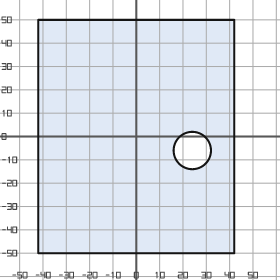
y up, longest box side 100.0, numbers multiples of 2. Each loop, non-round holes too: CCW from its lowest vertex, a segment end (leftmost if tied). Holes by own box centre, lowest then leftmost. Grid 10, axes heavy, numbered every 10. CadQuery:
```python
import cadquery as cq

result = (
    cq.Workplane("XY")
    .moveTo(-42.0, -50.0)
    .lineTo(42.0, -50.0)
    .lineTo(42.0, 50.0)
    .lineTo(-42.0, 50.0)
    .close()
    .moveTo(24.0, -6.0)
    .circle(8.0)
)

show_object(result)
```